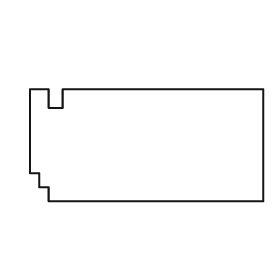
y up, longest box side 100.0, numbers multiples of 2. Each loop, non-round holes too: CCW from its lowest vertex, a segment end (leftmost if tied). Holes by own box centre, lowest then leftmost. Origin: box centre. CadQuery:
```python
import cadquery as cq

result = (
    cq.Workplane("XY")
    .moveTo(-42.0, -24.0)
    .lineTo(50.0, -24.0)
    .lineTo(50.0, 24.0)
    .lineTo(-36.0, 24.0)
    .lineTo(-36.0, 16.0)
    .lineTo(-42.0, 16.0)
    .lineTo(-42.0, 24.0)
    .lineTo(-50.0, 24.0)
    .lineTo(-50.0, -12.0)
    .lineTo(-46.0, -12.0)
    .lineTo(-46.0, -18.0)
    .lineTo(-42.0, -18.0)
    .close()
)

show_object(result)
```